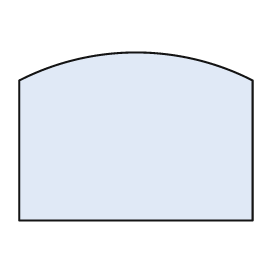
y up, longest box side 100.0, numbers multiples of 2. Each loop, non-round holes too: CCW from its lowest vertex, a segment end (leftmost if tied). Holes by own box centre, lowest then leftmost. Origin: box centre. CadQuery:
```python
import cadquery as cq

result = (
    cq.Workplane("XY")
    .moveTo(-50.0, -36.0)
    .lineTo(50.0, -36.0)
    .lineTo(50.0, 24.0)
    .threePointArc((0.0, 36.0), (-50.0, 24.0))
    .close()
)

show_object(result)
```